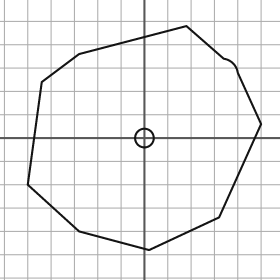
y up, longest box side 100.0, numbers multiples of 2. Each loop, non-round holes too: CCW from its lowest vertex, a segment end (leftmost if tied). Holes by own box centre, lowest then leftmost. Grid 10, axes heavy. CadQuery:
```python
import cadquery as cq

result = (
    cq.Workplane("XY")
    .moveTo(2.0, -48.0)
    .lineTo(32.0, -34.0)
    .lineTo(50.0, 6.0)
    .lineTo(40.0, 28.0)
    .threePointArc((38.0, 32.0), (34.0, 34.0))
    .lineTo(18.0, 48.0)
    .lineTo(-28.0, 36.0)
    .lineTo(-44.0, 24.0)
    .lineTo(-50.0, -20.0)
    .lineTo(-28.0, -40.0)
    .close()
    .moveTo(0.0, 0.0)
    .circle(4.0)
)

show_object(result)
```